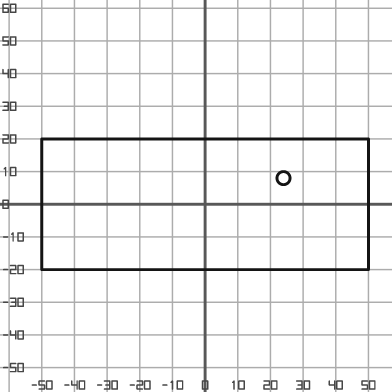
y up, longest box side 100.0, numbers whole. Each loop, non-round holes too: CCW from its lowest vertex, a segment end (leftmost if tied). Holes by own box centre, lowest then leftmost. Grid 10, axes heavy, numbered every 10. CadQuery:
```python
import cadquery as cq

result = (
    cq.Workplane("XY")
    .moveTo(-50.0, -20.0)
    .lineTo(50.0, -20.0)
    .lineTo(50.0, 20.0)
    .lineTo(-50.0, 20.0)
    .close()
    .moveTo(24.0, 8.0)
    .circle(2.0)
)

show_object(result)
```